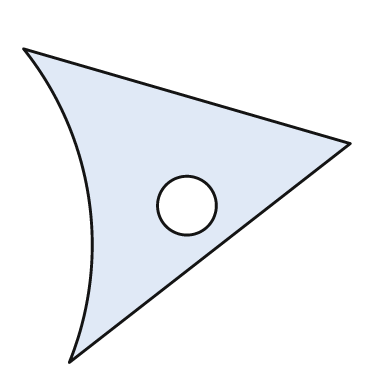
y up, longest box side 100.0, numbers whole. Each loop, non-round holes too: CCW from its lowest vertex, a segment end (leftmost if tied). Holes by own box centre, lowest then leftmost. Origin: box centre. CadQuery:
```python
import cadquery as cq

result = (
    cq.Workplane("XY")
    .moveTo(-36.0, -48.0)
    .lineTo(50.0, 19.0)
    .lineTo(-50.0, 48.0)
    .threePointArc((-30.0, 2.0), (-36.0, -48.0))
    .close()
    .moveTo(0.0, 0.0)
    .circle(9.0)
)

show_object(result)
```